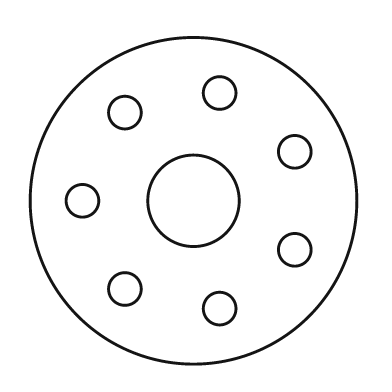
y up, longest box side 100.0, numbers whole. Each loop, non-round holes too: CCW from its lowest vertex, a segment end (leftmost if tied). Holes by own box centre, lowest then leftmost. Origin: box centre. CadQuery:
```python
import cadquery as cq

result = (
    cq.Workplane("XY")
    .moveTo(0.0, 0.0)
    .circle(50.0)
    .moveTo(8.0, -33.0)
    .circle(5.0)
    .moveTo(-21.0, -27.0)
    .circle(5.0)
    .moveTo(31.0, -15.0)
    .circle(5.0)
    .moveTo(-34.0, 0.0)
    .circle(5.0)
    .moveTo(0.0, 0.0)
    .circle(14.0)
    .moveTo(31.0, 15.0)
    .circle(5.0)
    .moveTo(-21.0, 27.0)
    .circle(5.0)
    .moveTo(8.0, 33.0)
    .circle(5.0)
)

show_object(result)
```